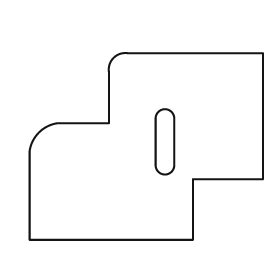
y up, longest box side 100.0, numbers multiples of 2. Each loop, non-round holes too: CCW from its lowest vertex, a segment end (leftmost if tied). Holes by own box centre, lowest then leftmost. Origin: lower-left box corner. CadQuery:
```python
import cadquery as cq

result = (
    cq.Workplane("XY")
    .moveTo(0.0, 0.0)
    .lineTo(70.0, 0.0)
    .lineTo(70.0, 26.0)
    .lineTo(100.0, 26.0)
    .lineTo(100.0, 80.0)
    .lineTo(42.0, 80.0)
    .threePointArc((36.0, 78.0), (34.0, 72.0))
    .lineTo(34.0, 50.0)
    .lineTo(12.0, 50.0)
    .threePointArc((4.0, 46.0), (0.0, 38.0))
    .close()
    .moveTo(54.0, 32.0)
    .threePointArc((58.0, 28.0), (62.0, 32.0))
    .lineTo(62.0, 52.0)
    .threePointArc((58.0, 56.0), (54.0, 52.0))
    .close()
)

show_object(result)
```